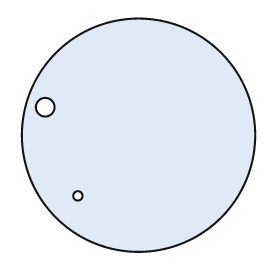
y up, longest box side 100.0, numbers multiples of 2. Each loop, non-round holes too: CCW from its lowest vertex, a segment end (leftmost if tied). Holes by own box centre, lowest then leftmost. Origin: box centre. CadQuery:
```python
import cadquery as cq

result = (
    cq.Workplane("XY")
    .moveTo(0.0, 0.0)
    .circle(50.0)
    .moveTo(-26.0, -26.0)
    .circle(2.0)
    .moveTo(-40.0, 12.0)
    .circle(4.0)
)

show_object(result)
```